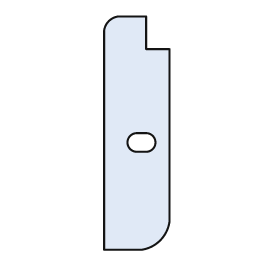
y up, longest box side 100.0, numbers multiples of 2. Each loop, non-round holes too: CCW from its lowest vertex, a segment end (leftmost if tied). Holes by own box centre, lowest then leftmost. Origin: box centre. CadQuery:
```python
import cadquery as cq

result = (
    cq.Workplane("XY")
    .moveTo(-14.0, -50.0)
    .lineTo(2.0, -50.0)
    .threePointArc((10.0, -46.0), (14.0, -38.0))
    .lineTo(14.0, 36.0)
    .lineTo(4.0, 36.0)
    .lineTo(4.0, 50.0)
    .lineTo(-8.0, 50.0)
    .threePointArc((-12.0, 48.0), (-14.0, 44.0))
    .close()
    .moveTo(0.0, -8.0)
    .lineTo(4.0, -8.0)
    .threePointArc((8.0, -4.0), (4.0, 0.0))
    .lineTo(0.0, 0.0)
    .threePointArc((-4.0, -4.0), (0.0, -8.0))
    .close()
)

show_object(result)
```